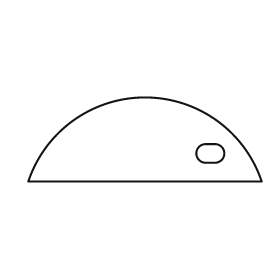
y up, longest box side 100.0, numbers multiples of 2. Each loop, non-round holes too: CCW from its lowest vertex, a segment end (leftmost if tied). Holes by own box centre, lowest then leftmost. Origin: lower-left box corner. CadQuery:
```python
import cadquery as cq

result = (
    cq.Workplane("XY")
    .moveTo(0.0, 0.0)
    .lineTo(100.0, 0.0)
    .threePointArc((50.0, 36.0), (0.0, 0.0))
    .close()
    .moveTo(76.0, 8.0)
    .lineTo(80.0, 8.0)
    .threePointArc((84.0, 12.0), (80.0, 16.0))
    .lineTo(76.0, 16.0)
    .threePointArc((72.0, 12.0), (76.0, 8.0))
    .close()
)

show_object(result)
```